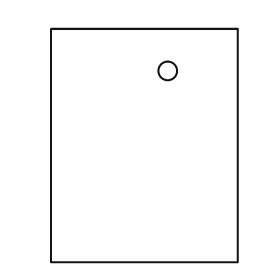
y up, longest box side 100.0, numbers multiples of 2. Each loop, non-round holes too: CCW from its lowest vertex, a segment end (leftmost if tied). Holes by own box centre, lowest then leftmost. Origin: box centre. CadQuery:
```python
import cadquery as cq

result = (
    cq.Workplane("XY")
    .moveTo(-40.0, -50.0)
    .lineTo(40.0, -50.0)
    .lineTo(40.0, 50.0)
    .lineTo(-40.0, 50.0)
    .close()
    .moveTo(10.0, 32.0)
    .circle(4.0)
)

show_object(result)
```